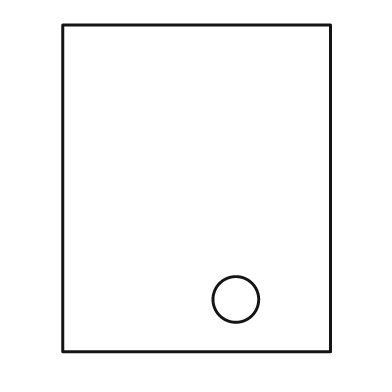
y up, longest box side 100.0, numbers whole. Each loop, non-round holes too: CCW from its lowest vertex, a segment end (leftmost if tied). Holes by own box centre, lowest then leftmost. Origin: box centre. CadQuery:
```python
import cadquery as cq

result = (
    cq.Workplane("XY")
    .moveTo(-41.0, -50.0)
    .lineTo(41.0, -50.0)
    .lineTo(41.0, 50.0)
    .lineTo(-41.0, 50.0)
    .close()
    .moveTo(12.0, -34.0)
    .circle(7.0)
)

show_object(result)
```